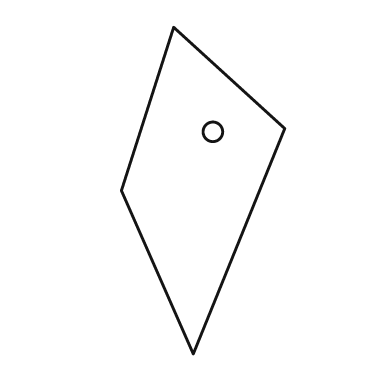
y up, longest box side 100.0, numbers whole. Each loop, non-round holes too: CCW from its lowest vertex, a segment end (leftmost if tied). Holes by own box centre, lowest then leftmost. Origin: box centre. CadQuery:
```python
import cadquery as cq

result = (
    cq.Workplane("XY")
    .moveTo(-3.0, -50.0)
    .lineTo(25.0, 19.0)
    .lineTo(-9.0, 50.0)
    .lineTo(-25.0, 0.0)
    .close()
    .moveTo(3.0, 18.0)
    .circle(3.0)
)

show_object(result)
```